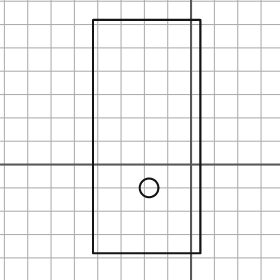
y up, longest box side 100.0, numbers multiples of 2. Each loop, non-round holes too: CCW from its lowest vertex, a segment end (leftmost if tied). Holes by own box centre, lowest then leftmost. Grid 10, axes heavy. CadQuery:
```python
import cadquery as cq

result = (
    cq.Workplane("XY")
    .moveTo(-42.0, -38.0)
    .lineTo(4.0, -38.0)
    .lineTo(4.0, 62.0)
    .lineTo(-42.0, 62.0)
    .close()
    .moveTo(-18.0, -10.0)
    .circle(4.0)
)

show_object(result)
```